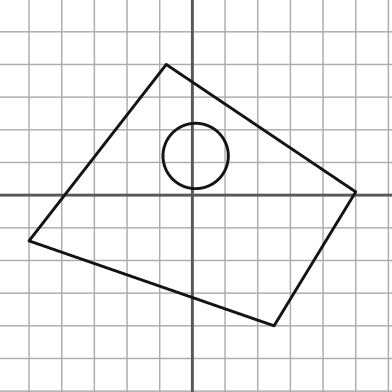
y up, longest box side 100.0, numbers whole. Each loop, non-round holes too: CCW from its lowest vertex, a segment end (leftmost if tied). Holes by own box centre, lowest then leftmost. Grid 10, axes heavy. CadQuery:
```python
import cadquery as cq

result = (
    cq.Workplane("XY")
    .moveTo(25.0, -40.0)
    .lineTo(50.0, 1.0)
    .lineTo(-8.0, 40.0)
    .lineTo(-50.0, -14.0)
    .close()
    .moveTo(1.0, 12.0)
    .circle(10.0)
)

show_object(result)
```